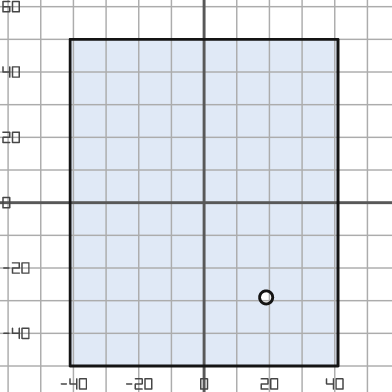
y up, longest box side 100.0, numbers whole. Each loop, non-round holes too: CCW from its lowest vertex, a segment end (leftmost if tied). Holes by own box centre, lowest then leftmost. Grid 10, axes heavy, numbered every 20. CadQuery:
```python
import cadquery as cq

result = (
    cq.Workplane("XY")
    .moveTo(-41.0, -50.0)
    .lineTo(41.0, -50.0)
    .lineTo(41.0, 50.0)
    .lineTo(-41.0, 50.0)
    .close()
    .moveTo(19.0, -29.0)
    .circle(2.0)
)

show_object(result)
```